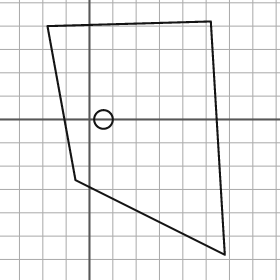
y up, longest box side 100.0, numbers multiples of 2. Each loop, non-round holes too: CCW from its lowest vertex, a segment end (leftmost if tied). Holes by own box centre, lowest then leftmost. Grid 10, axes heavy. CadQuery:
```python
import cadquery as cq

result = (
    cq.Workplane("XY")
    .moveTo(58.0, -58.0)
    .lineTo(52.0, 42.0)
    .lineTo(-18.0, 40.0)
    .lineTo(-6.0, -26.0)
    .close()
    .moveTo(6.0, 0.0)
    .circle(4.0)
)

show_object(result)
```